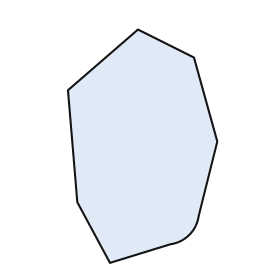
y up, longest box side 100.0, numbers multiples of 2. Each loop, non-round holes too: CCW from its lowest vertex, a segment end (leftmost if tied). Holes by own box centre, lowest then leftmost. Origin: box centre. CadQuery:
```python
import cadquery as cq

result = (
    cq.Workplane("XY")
    .moveTo(-14.0, -50.0)
    .lineTo(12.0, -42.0)
    .threePointArc((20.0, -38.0), (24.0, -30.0))
    .lineTo(32.0, 2.0)
    .lineTo(22.0, 38.0)
    .lineTo(-2.0, 50.0)
    .lineTo(-32.0, 24.0)
    .lineTo(-28.0, -24.0)
    .close()
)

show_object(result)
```